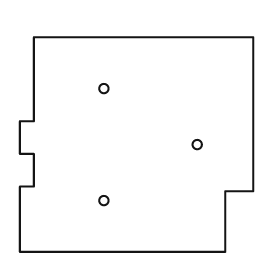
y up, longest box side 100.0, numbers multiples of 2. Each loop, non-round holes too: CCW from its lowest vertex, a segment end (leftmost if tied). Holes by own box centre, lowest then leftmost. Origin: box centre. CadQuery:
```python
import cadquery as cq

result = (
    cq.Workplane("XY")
    .moveTo(-50.0, -46.0)
    .lineTo(38.0, -46.0)
    .lineTo(38.0, -20.0)
    .lineTo(50.0, -20.0)
    .lineTo(50.0, 46.0)
    .lineTo(-44.0, 46.0)
    .lineTo(-44.0, 10.0)
    .lineTo(-50.0, 10.0)
    .lineTo(-50.0, -4.0)
    .lineTo(-44.0, -4.0)
    .lineTo(-44.0, -18.0)
    .lineTo(-50.0, -18.0)
    .close()
    .moveTo(-14.0, -24.0)
    .circle(2.0)
    .moveTo(26.0, 0.0)
    .circle(2.0)
    .moveTo(-14.0, 24.0)
    .circle(2.0)
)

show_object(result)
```